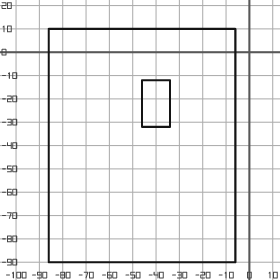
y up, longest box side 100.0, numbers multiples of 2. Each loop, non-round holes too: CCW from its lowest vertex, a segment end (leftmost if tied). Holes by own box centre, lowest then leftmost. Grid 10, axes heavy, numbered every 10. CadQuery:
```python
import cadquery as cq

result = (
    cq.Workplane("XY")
    .moveTo(-86.0, -90.0)
    .lineTo(-6.0, -90.0)
    .lineTo(-6.0, 10.0)
    .lineTo(-86.0, 10.0)
    .close()
    .moveTo(-46.0, -32.0)
    .lineTo(-34.0, -32.0)
    .lineTo(-34.0, -12.0)
    .lineTo(-46.0, -12.0)
    .close()
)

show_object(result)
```